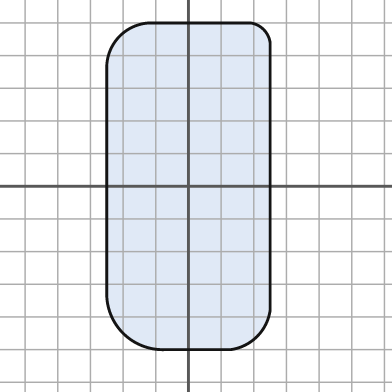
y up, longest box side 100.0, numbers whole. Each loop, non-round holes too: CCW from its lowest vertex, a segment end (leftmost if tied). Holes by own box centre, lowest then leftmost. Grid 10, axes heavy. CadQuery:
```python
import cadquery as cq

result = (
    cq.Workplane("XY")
    .moveTo(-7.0, -50.0)
    .lineTo(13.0, -50.0)
    .threePointArc((21.0, -46.0), (25.0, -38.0))
    .lineTo(25.0, 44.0)
    .threePointArc((23.0, 48.0), (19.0, 50.0))
    .lineTo(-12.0, 50.0)
    .threePointArc((-21.0, 46.0), (-25.0, 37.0))
    .lineTo(-25.0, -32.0)
    .threePointArc((-20.0, -45.0), (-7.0, -50.0))
    .close()
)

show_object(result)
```